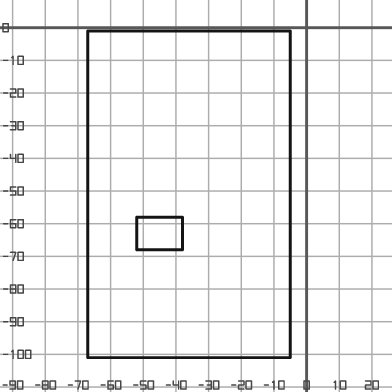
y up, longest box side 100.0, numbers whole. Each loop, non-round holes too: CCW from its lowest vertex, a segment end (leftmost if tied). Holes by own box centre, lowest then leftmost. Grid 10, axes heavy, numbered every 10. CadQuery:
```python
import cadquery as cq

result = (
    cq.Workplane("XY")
    .moveTo(-67.0, -101.0)
    .lineTo(-5.0, -101.0)
    .lineTo(-5.0, -1.0)
    .lineTo(-67.0, -1.0)
    .close()
    .moveTo(-52.0, -68.0)
    .lineTo(-38.0, -68.0)
    .lineTo(-38.0, -58.0)
    .lineTo(-52.0, -58.0)
    .close()
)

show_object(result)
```